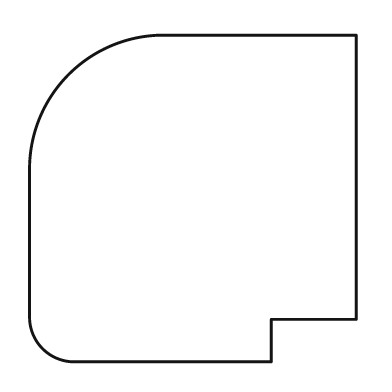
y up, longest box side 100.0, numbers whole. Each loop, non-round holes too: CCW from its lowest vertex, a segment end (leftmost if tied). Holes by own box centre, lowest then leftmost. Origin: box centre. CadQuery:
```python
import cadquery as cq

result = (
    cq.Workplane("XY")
    .moveTo(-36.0, -50.0)
    .lineTo(24.0, -50.0)
    .lineTo(24.0, -37.0)
    .lineTo(50.0, -37.0)
    .lineTo(50.0, 50.0)
    .lineTo(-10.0, 50.0)
    .threePointArc((-38.0, 38.0), (-50.0, 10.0))
    .lineTo(-50.0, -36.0)
    .threePointArc((-46.0, -46.0), (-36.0, -50.0))
    .close()
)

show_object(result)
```